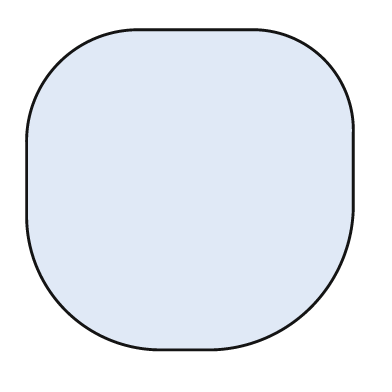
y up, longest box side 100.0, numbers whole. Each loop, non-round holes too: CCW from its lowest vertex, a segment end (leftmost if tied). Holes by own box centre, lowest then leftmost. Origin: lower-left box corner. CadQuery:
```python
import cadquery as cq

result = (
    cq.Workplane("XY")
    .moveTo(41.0, 0.0)
    .lineTo(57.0, 0.0)
    .threePointArc((87.0, 13.0), (100.0, 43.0))
    .lineTo(100.0, 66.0)
    .threePointArc((91.0, 89.0), (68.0, 98.0))
    .lineTo(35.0, 98.0)
    .threePointArc((10.0, 88.0), (0.0, 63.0))
    .lineTo(0.0, 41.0)
    .threePointArc((12.0, 12.0), (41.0, 0.0))
    .close()
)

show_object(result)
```